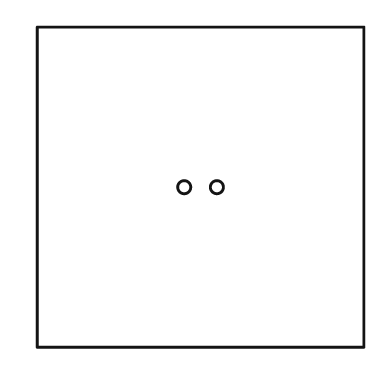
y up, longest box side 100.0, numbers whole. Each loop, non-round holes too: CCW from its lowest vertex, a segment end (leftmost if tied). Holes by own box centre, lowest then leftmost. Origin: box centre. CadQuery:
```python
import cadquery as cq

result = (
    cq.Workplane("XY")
    .moveTo(-50.0, -49.0)
    .lineTo(50.0, -49.0)
    .lineTo(50.0, 49.0)
    .lineTo(-50.0, 49.0)
    .close()
    .moveTo(-5.0, 0.0)
    .circle(2.0)
    .moveTo(5.0, 0.0)
    .circle(2.0)
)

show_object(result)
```